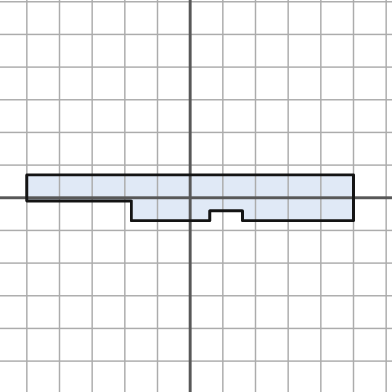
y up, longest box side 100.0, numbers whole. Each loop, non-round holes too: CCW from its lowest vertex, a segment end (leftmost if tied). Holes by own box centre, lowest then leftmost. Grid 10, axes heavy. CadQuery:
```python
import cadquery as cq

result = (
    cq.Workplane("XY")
    .moveTo(-18.0, -7.0)
    .lineTo(6.0, -7.0)
    .lineTo(6.0, -4.0)
    .lineTo(16.0, -4.0)
    .lineTo(16.0, -7.0)
    .lineTo(50.0, -7.0)
    .lineTo(50.0, 7.0)
    .lineTo(-50.0, 7.0)
    .lineTo(-50.0, -1.0)
    .lineTo(-18.0, -1.0)
    .close()
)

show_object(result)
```